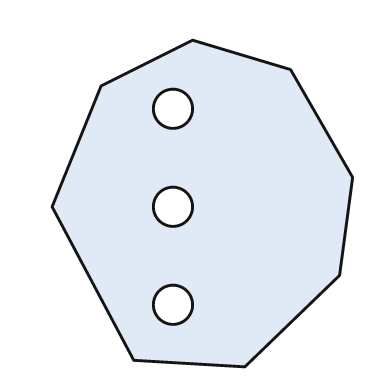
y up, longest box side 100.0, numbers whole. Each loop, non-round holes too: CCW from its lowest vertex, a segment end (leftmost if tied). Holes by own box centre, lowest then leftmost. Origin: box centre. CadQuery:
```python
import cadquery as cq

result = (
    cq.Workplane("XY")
    .moveTo(13.0, -50.0)
    .lineTo(42.0, -22.0)
    .lineTo(46.0, 8.0)
    .lineTo(27.0, 41.0)
    .lineTo(-3.0, 50.0)
    .lineTo(-31.0, 36.0)
    .lineTo(-46.0, -1.0)
    .lineTo(-21.0, -48.0)
    .close()
    .moveTo(-9.0, -31.0)
    .circle(6.0)
    .moveTo(-9.0, -1.0)
    .circle(6.0)
    .moveTo(-9.0, 29.0)
    .circle(6.0)
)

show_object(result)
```